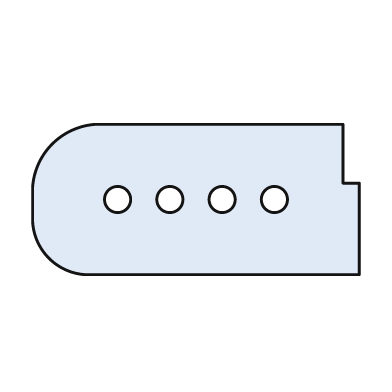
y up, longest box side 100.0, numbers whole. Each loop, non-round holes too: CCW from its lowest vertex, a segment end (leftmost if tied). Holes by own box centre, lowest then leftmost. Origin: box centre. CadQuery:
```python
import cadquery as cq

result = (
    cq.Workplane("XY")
    .moveTo(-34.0, -23.0)
    .lineTo(50.0, -23.0)
    .lineTo(50.0, 5.0)
    .lineTo(45.0, 5.0)
    .lineTo(45.0, 23.0)
    .lineTo(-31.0, 23.0)
    .threePointArc((-44.0, 17.0), (-50.0, 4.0))
    .lineTo(-50.0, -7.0)
    .threePointArc((-45.0, -18.0), (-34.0, -23.0))
    .close()
    .moveTo(-24.0, 0.0)
    .circle(4.0)
    .moveTo(-8.0, 0.0)
    .circle(4.0)
    .moveTo(8.0, 0.0)
    .circle(4.0)
    .moveTo(24.0, 0.0)
    .circle(4.0)
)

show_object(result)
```